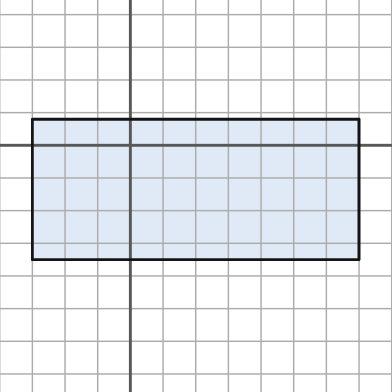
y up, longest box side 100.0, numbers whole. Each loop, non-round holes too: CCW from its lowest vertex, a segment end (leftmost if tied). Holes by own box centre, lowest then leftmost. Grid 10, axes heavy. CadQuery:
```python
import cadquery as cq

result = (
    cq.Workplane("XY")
    .moveTo(-30.0, -35.0)
    .lineTo(70.0, -35.0)
    .lineTo(70.0, 8.0)
    .lineTo(-30.0, 8.0)
    .close()
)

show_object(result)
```